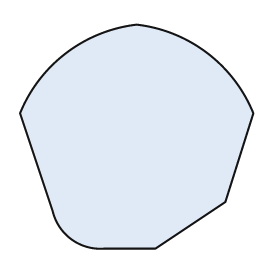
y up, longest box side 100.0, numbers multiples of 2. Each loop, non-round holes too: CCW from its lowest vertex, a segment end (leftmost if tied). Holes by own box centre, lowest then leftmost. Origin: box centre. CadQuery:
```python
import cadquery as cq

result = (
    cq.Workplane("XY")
    .moveTo(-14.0, -48.0)
    .lineTo(8.0, -48.0)
    .lineTo(38.0, -28.0)
    .lineTo(50.0, 10.0)
    .threePointArc((30.0, 36.0), (0.0, 48.0))
    .threePointArc((-30.0, 36.0), (-50.0, 10.0))
    .lineTo(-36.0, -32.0)
    .threePointArc((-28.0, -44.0), (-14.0, -48.0))
    .close()
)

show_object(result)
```